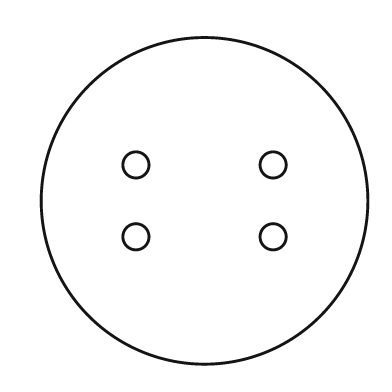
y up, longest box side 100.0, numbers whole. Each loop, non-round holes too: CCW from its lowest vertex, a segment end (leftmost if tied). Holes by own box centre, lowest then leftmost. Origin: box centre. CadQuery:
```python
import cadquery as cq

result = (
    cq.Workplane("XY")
    .moveTo(0.0, 0.0)
    .circle(50.0)
    .moveTo(-21.0, -11.0)
    .circle(4.0)
    .moveTo(21.0, -11.0)
    .circle(4.0)
    .moveTo(-21.0, 11.0)
    .circle(4.0)
    .moveTo(21.0, 11.0)
    .circle(4.0)
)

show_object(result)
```